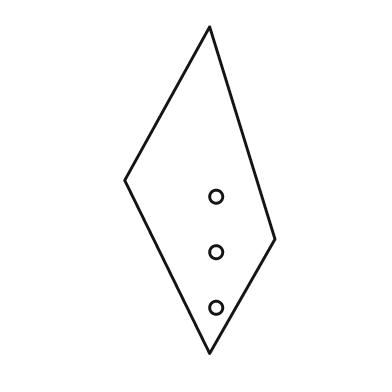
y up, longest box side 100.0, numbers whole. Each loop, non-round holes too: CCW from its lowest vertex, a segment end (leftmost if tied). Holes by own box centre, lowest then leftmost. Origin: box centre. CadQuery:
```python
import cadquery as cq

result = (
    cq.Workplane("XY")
    .moveTo(3.0, -50.0)
    .lineTo(23.0, -15.0)
    .lineTo(3.0, 50.0)
    .lineTo(-23.0, 3.0)
    .close()
    .moveTo(5.0, -36.0)
    .circle(2.0)
    .moveTo(5.0, -19.0)
    .circle(2.0)
    .moveTo(5.0, -2.0)
    .circle(2.0)
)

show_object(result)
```